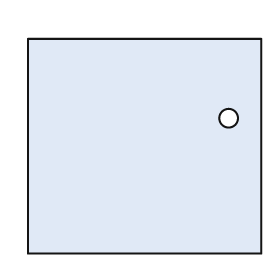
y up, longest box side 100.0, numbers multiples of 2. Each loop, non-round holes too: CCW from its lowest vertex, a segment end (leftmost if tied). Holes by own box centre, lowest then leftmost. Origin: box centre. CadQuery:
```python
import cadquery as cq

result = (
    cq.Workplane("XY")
    .moveTo(-50.0, -46.0)
    .lineTo(50.0, -46.0)
    .lineTo(50.0, 46.0)
    .lineTo(-50.0, 46.0)
    .close()
    .moveTo(36.0, 12.0)
    .circle(4.0)
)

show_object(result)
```